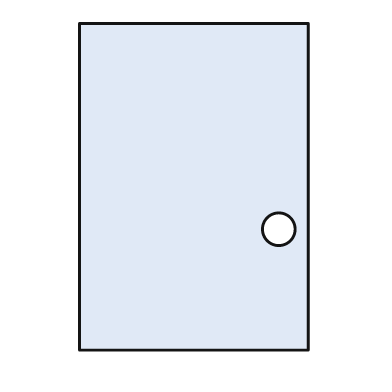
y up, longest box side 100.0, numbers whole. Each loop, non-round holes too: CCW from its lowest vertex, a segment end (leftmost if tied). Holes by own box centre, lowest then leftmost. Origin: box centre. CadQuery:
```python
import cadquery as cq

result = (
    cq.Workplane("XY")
    .moveTo(-35.0, -50.0)
    .lineTo(35.0, -50.0)
    .lineTo(35.0, 50.0)
    .lineTo(-35.0, 50.0)
    .close()
    .moveTo(26.0, -13.0)
    .circle(5.0)
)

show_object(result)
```